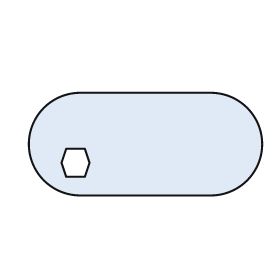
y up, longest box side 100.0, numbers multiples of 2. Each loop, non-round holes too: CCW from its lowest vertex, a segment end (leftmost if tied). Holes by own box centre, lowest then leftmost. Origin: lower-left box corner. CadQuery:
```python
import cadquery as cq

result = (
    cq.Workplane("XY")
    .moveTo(22.0, 0.0)
    .lineTo(78.0, 0.0)
    .threePointArc((100.0, 22.0), (78.0, 44.0))
    .lineTo(22.0, 44.0)
    .threePointArc((0.0, 22.0), (22.0, 0.0))
    .close()
    .moveTo(16.0, 8.0)
    .lineTo(24.0, 8.0)
    .lineTo(26.0, 14.0)
    .lineTo(24.0, 20.0)
    .lineTo(16.0, 20.0)
    .lineTo(14.0, 14.0)
    .close()
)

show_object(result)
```